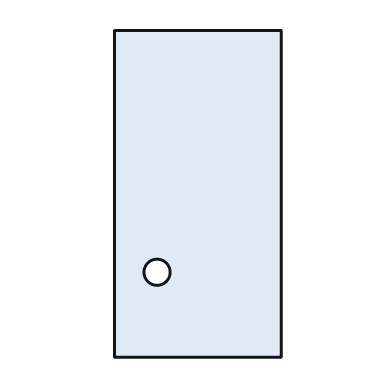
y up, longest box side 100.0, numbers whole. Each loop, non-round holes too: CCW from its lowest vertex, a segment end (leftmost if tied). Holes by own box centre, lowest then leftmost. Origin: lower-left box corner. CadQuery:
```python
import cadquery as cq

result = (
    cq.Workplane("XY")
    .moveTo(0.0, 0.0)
    .lineTo(51.0, 0.0)
    .lineTo(51.0, 100.0)
    .lineTo(0.0, 100.0)
    .close()
    .moveTo(13.0, 26.0)
    .circle(4.0)
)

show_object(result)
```